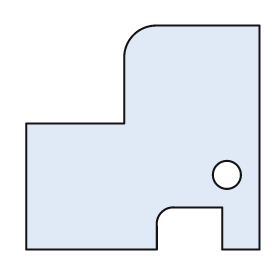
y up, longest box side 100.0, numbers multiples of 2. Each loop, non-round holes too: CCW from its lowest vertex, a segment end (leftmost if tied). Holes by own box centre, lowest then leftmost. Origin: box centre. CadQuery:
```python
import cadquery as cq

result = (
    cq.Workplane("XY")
    .moveTo(-50.0, -48.0)
    .lineTo(6.0, -48.0)
    .lineTo(6.0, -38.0)
    .threePointArc((8.0, -32.0), (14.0, -30.0))
    .lineTo(34.0, -30.0)
    .lineTo(34.0, -48.0)
    .lineTo(50.0, -48.0)
    .lineTo(50.0, 48.0)
    .lineTo(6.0, 48.0)
    .threePointArc((-4.0, 44.0), (-8.0, 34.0))
    .lineTo(-8.0, 6.0)
    .lineTo(-50.0, 6.0)
    .close()
    .moveTo(36.0, -16.0)
    .circle(6.0)
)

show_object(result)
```